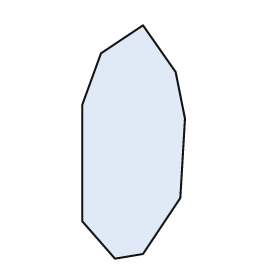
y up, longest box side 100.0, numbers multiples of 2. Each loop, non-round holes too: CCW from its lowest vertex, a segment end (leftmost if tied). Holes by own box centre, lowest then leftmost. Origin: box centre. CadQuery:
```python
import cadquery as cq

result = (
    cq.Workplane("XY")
    .moveTo(-8.0, -50.0)
    .lineTo(4.0, -48.0)
    .lineTo(20.0, -24.0)
    .lineTo(22.0, 10.0)
    .lineTo(18.0, 30.0)
    .lineTo(4.0, 50.0)
    .lineTo(-14.0, 38.0)
    .lineTo(-22.0, 16.0)
    .lineTo(-22.0, -34.0)
    .close()
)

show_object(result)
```